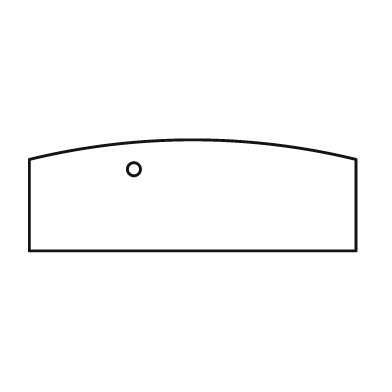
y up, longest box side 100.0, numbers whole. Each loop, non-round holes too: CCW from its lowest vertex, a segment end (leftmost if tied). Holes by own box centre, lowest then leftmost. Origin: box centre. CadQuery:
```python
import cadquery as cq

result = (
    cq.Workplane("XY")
    .moveTo(-50.0, -17.0)
    .lineTo(50.0, -17.0)
    .lineTo(50.0, 11.0)
    .threePointArc((0.0, 17.0), (-50.0, 11.0))
    .close()
    .moveTo(-18.0, 8.0)
    .circle(2.0)
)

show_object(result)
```